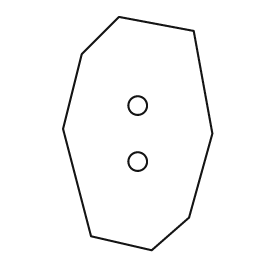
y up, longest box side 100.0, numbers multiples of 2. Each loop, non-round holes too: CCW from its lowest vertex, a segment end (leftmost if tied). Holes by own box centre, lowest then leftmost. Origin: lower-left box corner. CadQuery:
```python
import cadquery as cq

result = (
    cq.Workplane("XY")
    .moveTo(38.0, 0.0)
    .lineTo(54.0, 14.0)
    .lineTo(64.0, 50.0)
    .lineTo(56.0, 94.0)
    .lineTo(24.0, 100.0)
    .lineTo(8.0, 84.0)
    .lineTo(0.0, 52.0)
    .lineTo(12.0, 6.0)
    .close()
    .moveTo(32.0, 38.0)
    .circle(4.0)
    .moveTo(32.0, 62.0)
    .circle(4.0)
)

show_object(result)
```